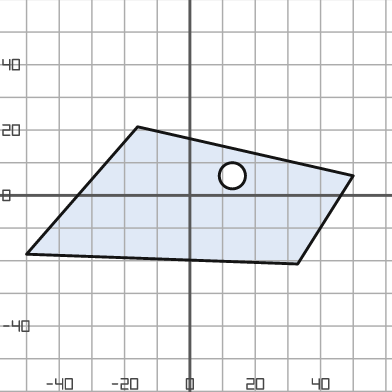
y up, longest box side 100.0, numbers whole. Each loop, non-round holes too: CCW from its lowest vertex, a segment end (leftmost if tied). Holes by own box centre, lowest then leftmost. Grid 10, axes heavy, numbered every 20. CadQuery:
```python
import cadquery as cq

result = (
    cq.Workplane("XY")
    .moveTo(33.0, -21.0)
    .lineTo(50.0, 6.0)
    .lineTo(-16.0, 21.0)
    .lineTo(-50.0, -18.0)
    .close()
    .moveTo(13.0, 6.0)
    .circle(4.0)
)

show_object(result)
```